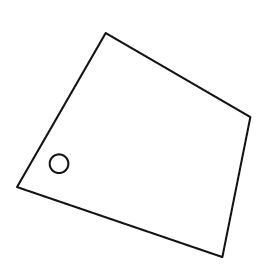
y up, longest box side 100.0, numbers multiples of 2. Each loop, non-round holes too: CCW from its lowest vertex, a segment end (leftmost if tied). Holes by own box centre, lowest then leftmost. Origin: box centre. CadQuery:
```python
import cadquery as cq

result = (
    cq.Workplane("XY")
    .moveTo(38.0, -48.0)
    .lineTo(50.0, 12.0)
    .lineTo(-12.0, 48.0)
    .lineTo(-50.0, -18.0)
    .close()
    .moveTo(-32.0, -8.0)
    .circle(4.0)
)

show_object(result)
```